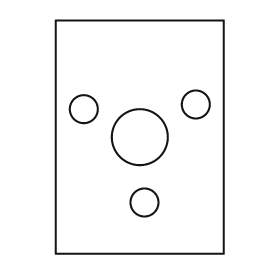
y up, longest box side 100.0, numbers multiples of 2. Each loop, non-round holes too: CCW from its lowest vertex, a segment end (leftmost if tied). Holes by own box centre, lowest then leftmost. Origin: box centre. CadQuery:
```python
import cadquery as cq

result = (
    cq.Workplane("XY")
    .moveTo(-36.0, -50.0)
    .lineTo(36.0, -50.0)
    .lineTo(36.0, 50.0)
    .lineTo(-36.0, 50.0)
    .close()
    .moveTo(2.0, -28.0)
    .circle(6.0)
    .moveTo(0.0, 0.0)
    .circle(12.0)
    .moveTo(-24.0, 12.0)
    .circle(6.0)
    .moveTo(24.0, 14.0)
    .circle(6.0)
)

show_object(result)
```